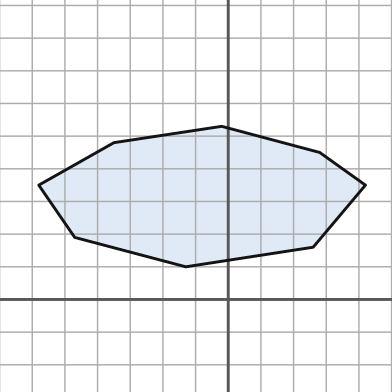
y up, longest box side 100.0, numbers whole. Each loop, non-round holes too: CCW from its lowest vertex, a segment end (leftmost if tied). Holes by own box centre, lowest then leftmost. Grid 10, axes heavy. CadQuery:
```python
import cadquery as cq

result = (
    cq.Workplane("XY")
    .moveTo(-13.0, 10.0)
    .lineTo(26.0, 16.0)
    .lineTo(42.0, 35.0)
    .lineTo(28.0, 45.0)
    .lineTo(-2.0, 53.0)
    .lineTo(-35.0, 48.0)
    .lineTo(-58.0, 35.0)
    .lineTo(-47.0, 19.0)
    .close()
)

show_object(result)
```